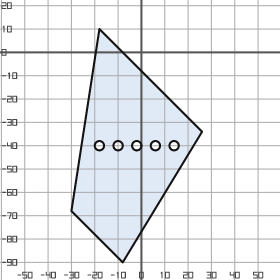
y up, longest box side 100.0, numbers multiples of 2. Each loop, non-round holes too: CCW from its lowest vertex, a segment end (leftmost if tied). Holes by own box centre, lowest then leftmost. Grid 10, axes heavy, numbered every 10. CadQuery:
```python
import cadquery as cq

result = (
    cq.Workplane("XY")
    .moveTo(-8.0, -90.0)
    .lineTo(26.0, -34.0)
    .lineTo(-18.0, 10.0)
    .lineTo(-30.0, -68.0)
    .close()
    .moveTo(-18.0, -40.0)
    .circle(2.0)
    .moveTo(-10.0, -40.0)
    .circle(2.0)
    .moveTo(-2.0, -40.0)
    .circle(2.0)
    .moveTo(6.0, -40.0)
    .circle(2.0)
    .moveTo(14.0, -40.0)
    .circle(2.0)
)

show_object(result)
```